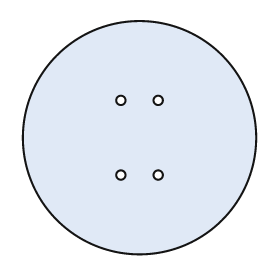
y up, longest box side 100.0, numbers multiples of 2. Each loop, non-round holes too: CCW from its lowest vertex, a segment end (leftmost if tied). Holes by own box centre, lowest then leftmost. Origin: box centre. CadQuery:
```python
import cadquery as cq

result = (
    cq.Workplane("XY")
    .moveTo(0.0, 0.0)
    .circle(50.0)
    .moveTo(-8.0, -16.0)
    .circle(2.0)
    .moveTo(8.0, -16.0)
    .circle(2.0)
    .moveTo(-8.0, 16.0)
    .circle(2.0)
    .moveTo(8.0, 16.0)
    .circle(2.0)
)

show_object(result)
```